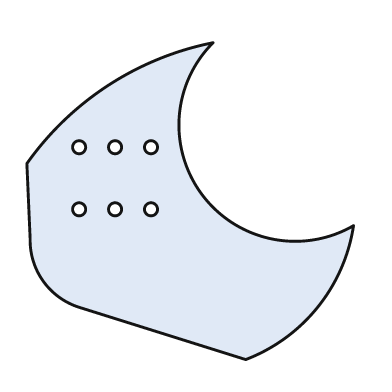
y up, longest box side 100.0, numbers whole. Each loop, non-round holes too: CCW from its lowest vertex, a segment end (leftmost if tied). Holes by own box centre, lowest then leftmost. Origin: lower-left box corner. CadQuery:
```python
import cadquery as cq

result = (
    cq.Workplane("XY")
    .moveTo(67.0, 0.0)
    .threePointArc((89.0, 16.0), (100.0, 41.0))
    .threePointArc((54.0, 50.0), (57.0, 97.0))
    .threePointArc((25.0, 84.0), (0.0, 60.0))
    .lineTo(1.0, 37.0)
    .threePointArc((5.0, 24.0), (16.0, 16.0))
    .close()
    .moveTo(16.0, 46.0)
    .circle(2.0)
    .moveTo(27.0, 46.0)
    .circle(2.0)
    .moveTo(38.0, 46.0)
    .circle(2.0)
    .moveTo(16.0, 65.0)
    .circle(2.0)
    .moveTo(27.0, 65.0)
    .circle(2.0)
    .moveTo(38.0, 65.0)
    .circle(2.0)
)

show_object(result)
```